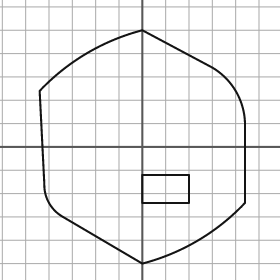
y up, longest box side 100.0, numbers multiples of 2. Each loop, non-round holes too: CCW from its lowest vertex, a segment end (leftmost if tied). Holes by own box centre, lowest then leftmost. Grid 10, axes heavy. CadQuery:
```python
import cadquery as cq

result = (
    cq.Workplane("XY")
    .moveTo(0.0, -50.0)
    .threePointArc((24.0, -40.0), (44.0, -24.0))
    .lineTo(44.0, 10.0)
    .threePointArc((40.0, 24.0), (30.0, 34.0))
    .lineTo(0.0, 50.0)
    .threePointArc((-24.0, 40.0), (-44.0, 24.0))
    .lineTo(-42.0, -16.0)
    .threePointArc((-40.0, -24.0), (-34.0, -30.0))
    .close()
    .moveTo(0.0, -24.0)
    .lineTo(20.0, -24.0)
    .lineTo(20.0, -12.0)
    .lineTo(0.0, -12.0)
    .close()
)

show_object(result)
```